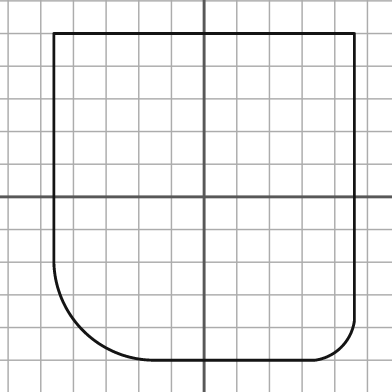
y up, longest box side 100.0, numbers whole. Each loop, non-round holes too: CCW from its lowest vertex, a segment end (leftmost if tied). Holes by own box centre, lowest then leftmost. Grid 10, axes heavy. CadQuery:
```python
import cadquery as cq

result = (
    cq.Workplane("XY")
    .moveTo(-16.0, -50.0)
    .lineTo(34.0, -50.0)
    .threePointArc((42.0, -46.0), (46.0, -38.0))
    .lineTo(46.0, 50.0)
    .lineTo(-46.0, 50.0)
    .lineTo(-46.0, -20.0)
    .threePointArc((-37.0, -41.0), (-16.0, -50.0))
    .close()
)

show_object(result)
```